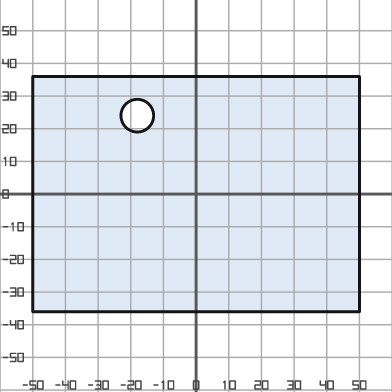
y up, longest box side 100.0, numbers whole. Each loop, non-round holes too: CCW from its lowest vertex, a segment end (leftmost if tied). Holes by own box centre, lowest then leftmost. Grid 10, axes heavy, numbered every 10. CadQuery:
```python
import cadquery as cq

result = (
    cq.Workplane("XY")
    .moveTo(-50.0, -36.0)
    .lineTo(50.0, -36.0)
    .lineTo(50.0, 36.0)
    .lineTo(-50.0, 36.0)
    .close()
    .moveTo(-18.0, 24.0)
    .circle(5.0)
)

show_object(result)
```